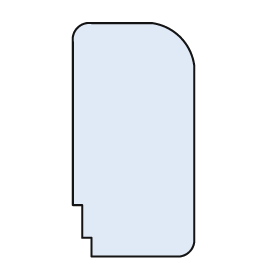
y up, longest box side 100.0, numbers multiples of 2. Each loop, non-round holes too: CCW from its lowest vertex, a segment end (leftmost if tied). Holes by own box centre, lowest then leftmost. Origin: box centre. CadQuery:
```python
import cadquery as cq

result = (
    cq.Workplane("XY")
    .moveTo(-18.0, -50.0)
    .lineTo(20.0, -50.0)
    .threePointArc((24.0, -48.0), (26.0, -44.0))
    .lineTo(26.0, 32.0)
    .threePointArc((20.0, 44.0), (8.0, 50.0))
    .lineTo(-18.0, 50.0)
    .threePointArc((-24.0, 48.0), (-26.0, 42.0))
    .lineTo(-26.0, -28.0)
    .lineTo(-22.0, -28.0)
    .lineTo(-22.0, -42.0)
    .lineTo(-18.0, -42.0)
    .close()
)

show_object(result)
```